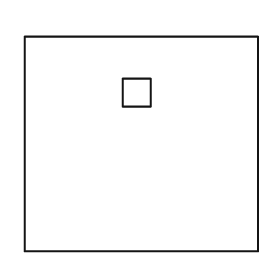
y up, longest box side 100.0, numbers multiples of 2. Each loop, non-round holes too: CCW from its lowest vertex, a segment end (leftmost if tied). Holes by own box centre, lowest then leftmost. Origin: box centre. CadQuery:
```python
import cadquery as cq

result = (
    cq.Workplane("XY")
    .moveTo(-50.0, -46.0)
    .lineTo(50.0, -46.0)
    .lineTo(50.0, 46.0)
    .lineTo(-50.0, 46.0)
    .close()
    .moveTo(-8.0, 16.0)
    .lineTo(4.0, 16.0)
    .lineTo(4.0, 28.0)
    .lineTo(-8.0, 28.0)
    .close()
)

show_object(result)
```